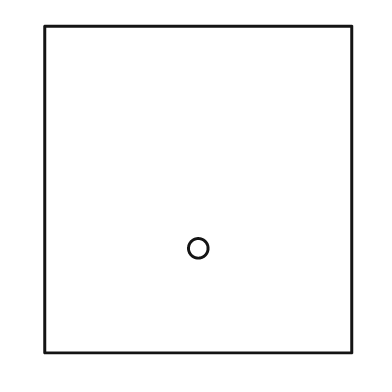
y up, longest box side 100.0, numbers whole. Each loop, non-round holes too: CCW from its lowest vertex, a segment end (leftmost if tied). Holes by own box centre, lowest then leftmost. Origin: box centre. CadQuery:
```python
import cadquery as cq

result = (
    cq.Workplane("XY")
    .moveTo(-47.0, -50.0)
    .lineTo(47.0, -50.0)
    .lineTo(47.0, 50.0)
    .lineTo(-47.0, 50.0)
    .close()
    .moveTo(0.0, -18.0)
    .circle(3.0)
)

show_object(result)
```